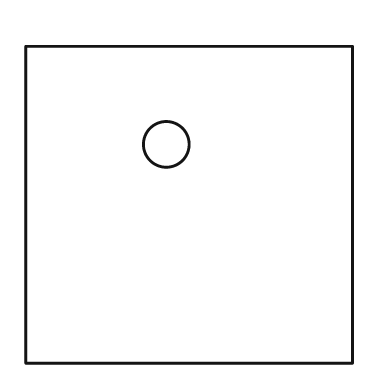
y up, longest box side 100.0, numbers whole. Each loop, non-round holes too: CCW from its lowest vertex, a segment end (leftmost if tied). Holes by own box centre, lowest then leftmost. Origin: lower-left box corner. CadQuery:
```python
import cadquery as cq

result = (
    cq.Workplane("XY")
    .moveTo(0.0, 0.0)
    .lineTo(100.0, 0.0)
    .lineTo(100.0, 97.0)
    .lineTo(0.0, 97.0)
    .close()
    .moveTo(43.0, 67.0)
    .circle(7.0)
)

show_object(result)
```